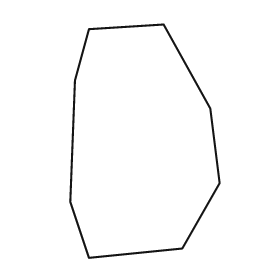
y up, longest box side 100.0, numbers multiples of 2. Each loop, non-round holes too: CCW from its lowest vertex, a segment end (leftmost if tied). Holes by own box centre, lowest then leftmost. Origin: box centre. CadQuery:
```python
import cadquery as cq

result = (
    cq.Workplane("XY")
    .moveTo(-24.0, -50.0)
    .lineTo(16.0, -46.0)
    .lineTo(32.0, -18.0)
    .lineTo(28.0, 14.0)
    .lineTo(8.0, 50.0)
    .lineTo(-24.0, 48.0)
    .lineTo(-30.0, 26.0)
    .lineTo(-32.0, -26.0)
    .close()
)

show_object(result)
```